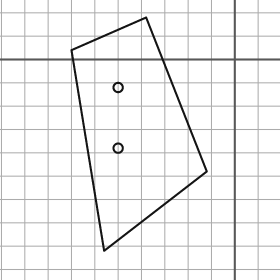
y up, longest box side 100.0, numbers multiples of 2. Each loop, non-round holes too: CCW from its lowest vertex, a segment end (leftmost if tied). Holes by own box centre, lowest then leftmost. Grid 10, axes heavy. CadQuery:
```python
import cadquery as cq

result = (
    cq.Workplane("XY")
    .moveTo(-56.0, -82.0)
    .lineTo(-12.0, -48.0)
    .lineTo(-38.0, 18.0)
    .lineTo(-70.0, 4.0)
    .close()
    .moveTo(-50.0, -38.0)
    .circle(2.0)
    .moveTo(-50.0, -12.0)
    .circle(2.0)
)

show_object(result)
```